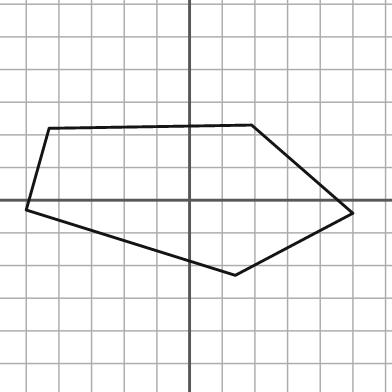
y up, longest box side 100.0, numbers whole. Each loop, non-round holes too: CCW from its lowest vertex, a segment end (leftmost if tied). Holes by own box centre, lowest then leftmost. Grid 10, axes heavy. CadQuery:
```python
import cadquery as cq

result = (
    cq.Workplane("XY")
    .moveTo(14.0, -23.0)
    .lineTo(50.0, -4.0)
    .lineTo(19.0, 23.0)
    .lineTo(-43.0, 22.0)
    .lineTo(-50.0, -3.0)
    .close()
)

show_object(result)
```